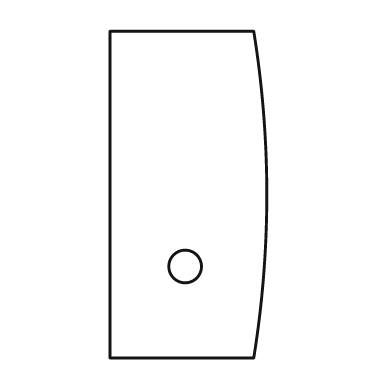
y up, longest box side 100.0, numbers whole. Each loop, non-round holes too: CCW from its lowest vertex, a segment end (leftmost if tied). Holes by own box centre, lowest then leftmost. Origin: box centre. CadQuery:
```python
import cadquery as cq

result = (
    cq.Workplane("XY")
    .moveTo(-24.0, -50.0)
    .lineTo(20.0, -50.0)
    .threePointArc((24.0, 0.0), (20.0, 50.0))
    .lineTo(-24.0, 50.0)
    .close()
    .moveTo(-1.0, -22.0)
    .circle(5.0)
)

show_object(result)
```